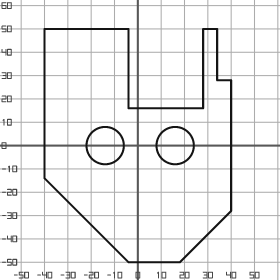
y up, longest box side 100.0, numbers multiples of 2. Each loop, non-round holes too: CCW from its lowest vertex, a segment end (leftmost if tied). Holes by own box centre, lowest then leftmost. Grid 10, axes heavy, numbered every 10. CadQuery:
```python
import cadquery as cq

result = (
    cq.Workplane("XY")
    .moveTo(-4.0, -50.0)
    .lineTo(18.0, -50.0)
    .lineTo(40.0, -28.0)
    .lineTo(40.0, 28.0)
    .lineTo(34.0, 28.0)
    .lineTo(34.0, 50.0)
    .lineTo(28.0, 50.0)
    .lineTo(28.0, 16.0)
    .lineTo(-4.0, 16.0)
    .lineTo(-4.0, 50.0)
    .lineTo(-40.0, 50.0)
    .lineTo(-40.0, -14.0)
    .close()
    .moveTo(-14.0, 0.0)
    .circle(8.0)
    .moveTo(16.0, 0.0)
    .circle(8.0)
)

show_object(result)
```